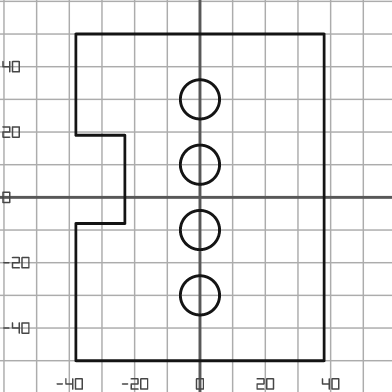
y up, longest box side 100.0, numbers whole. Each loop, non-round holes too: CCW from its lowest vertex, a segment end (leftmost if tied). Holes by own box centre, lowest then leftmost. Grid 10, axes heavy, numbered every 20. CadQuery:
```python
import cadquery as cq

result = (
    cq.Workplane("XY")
    .moveTo(-38.0, -50.0)
    .lineTo(38.0, -50.0)
    .lineTo(38.0, 50.0)
    .lineTo(-38.0, 50.0)
    .lineTo(-38.0, 19.0)
    .lineTo(-23.0, 19.0)
    .lineTo(-23.0, -8.0)
    .lineTo(-38.0, -8.0)
    .close()
    .moveTo(0.0, -30.0)
    .circle(6.0)
    .moveTo(0.0, -10.0)
    .circle(6.0)
    .moveTo(0.0, 10.0)
    .circle(6.0)
    .moveTo(0.0, 30.0)
    .circle(6.0)
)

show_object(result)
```